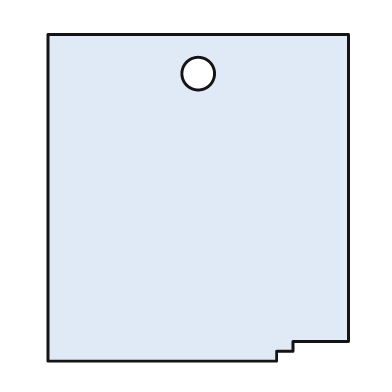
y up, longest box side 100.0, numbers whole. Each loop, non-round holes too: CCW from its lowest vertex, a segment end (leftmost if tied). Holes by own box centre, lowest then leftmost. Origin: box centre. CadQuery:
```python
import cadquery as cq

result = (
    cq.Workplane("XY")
    .moveTo(-46.0, -50.0)
    .lineTo(24.0, -50.0)
    .lineTo(24.0, -47.0)
    .lineTo(29.0, -47.0)
    .lineTo(29.0, -44.0)
    .lineTo(46.0, -44.0)
    .lineTo(46.0, 50.0)
    .lineTo(-46.0, 50.0)
    .close()
    .moveTo(0.0, 38.0)
    .circle(5.0)
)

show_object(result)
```